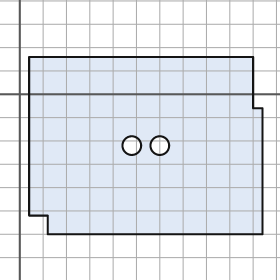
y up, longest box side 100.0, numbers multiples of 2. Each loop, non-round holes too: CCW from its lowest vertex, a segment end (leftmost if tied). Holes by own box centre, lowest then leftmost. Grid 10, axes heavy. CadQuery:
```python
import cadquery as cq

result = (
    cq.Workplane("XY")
    .moveTo(12.0, -60.0)
    .lineTo(104.0, -60.0)
    .lineTo(104.0, -6.0)
    .lineTo(100.0, -6.0)
    .lineTo(100.0, 16.0)
    .lineTo(4.0, 16.0)
    .lineTo(4.0, -52.0)
    .lineTo(12.0, -52.0)
    .close()
    .moveTo(48.0, -22.0)
    .circle(4.0)
    .moveTo(60.0, -22.0)
    .circle(4.0)
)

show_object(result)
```